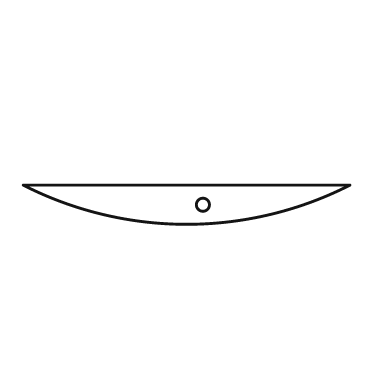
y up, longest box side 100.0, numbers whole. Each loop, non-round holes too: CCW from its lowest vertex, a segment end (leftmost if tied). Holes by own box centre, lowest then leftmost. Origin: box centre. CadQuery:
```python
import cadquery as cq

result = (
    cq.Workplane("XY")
    .moveTo(-50.0, 6.0)
    .threePointArc((0.0, -6.0), (50.0, 6.0))
    .close()
    .moveTo(5.0, 0.0)
    .circle(2.0)
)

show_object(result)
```